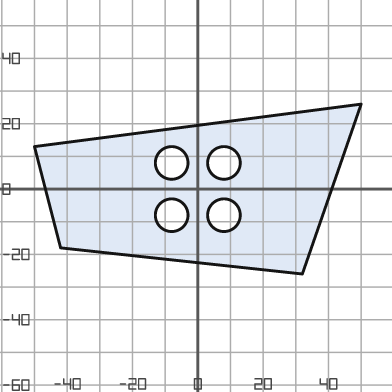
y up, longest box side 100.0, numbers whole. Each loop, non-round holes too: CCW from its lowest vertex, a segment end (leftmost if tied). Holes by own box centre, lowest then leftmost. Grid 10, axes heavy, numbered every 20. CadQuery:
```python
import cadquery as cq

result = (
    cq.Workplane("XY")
    .moveTo(32.0, -26.0)
    .lineTo(50.0, 26.0)
    .lineTo(-50.0, 13.0)
    .lineTo(-42.0, -18.0)
    .close()
    .moveTo(-8.0, -8.0)
    .circle(5.0)
    .moveTo(8.0, -8.0)
    .circle(5.0)
    .moveTo(-8.0, 8.0)
    .circle(5.0)
    .moveTo(8.0, 8.0)
    .circle(5.0)
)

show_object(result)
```